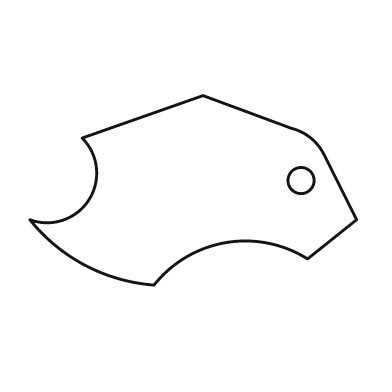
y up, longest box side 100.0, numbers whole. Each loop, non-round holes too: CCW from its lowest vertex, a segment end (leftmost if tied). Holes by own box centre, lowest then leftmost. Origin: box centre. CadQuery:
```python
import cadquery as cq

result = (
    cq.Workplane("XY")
    .moveTo(-12.0, -29.0)
    .threePointArc((10.0, -16.0), (35.0, -21.0))
    .lineTo(50.0, -9.0)
    .lineTo(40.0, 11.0)
    .threePointArc((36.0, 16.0), (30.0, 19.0))
    .lineTo(3.0, 29.0)
    .lineTo(-34.0, 16.0)
    .threePointArc((-32.0, -3.0), (-50.0, -9.0))
    .threePointArc((-33.0, -23.0), (-12.0, -29.0))
    .close()
    .moveTo(33.0, 3.0)
    .circle(4.0)
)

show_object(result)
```